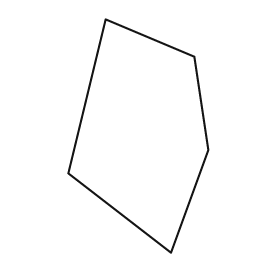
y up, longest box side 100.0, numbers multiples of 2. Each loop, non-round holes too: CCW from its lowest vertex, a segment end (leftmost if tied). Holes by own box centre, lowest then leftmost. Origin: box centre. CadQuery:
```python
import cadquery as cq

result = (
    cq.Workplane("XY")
    .moveTo(14.0, -50.0)
    .lineTo(30.0, -6.0)
    .lineTo(24.0, 34.0)
    .lineTo(-14.0, 50.0)
    .lineTo(-30.0, -16.0)
    .close()
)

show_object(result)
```